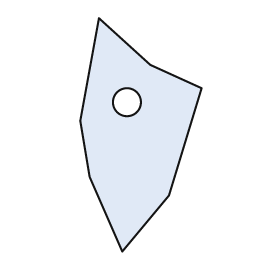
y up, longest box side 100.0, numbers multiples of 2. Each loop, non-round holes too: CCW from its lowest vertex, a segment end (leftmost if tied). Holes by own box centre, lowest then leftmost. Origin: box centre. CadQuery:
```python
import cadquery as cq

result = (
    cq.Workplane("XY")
    .moveTo(-8.0, -50.0)
    .lineTo(12.0, -26.0)
    .lineTo(26.0, 20.0)
    .lineTo(4.0, 30.0)
    .lineTo(-18.0, 50.0)
    .lineTo(-26.0, 6.0)
    .lineTo(-22.0, -18.0)
    .close()
    .moveTo(-6.0, 14.0)
    .circle(6.0)
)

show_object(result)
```